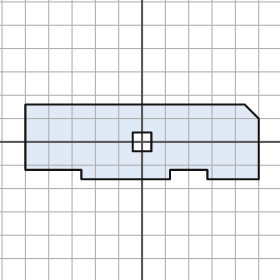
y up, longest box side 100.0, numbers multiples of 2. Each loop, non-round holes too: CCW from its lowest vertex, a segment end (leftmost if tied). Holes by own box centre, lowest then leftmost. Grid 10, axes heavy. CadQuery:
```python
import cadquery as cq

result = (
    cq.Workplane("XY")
    .moveTo(-26.0, -16.0)
    .lineTo(12.0, -16.0)
    .lineTo(12.0, -12.0)
    .lineTo(28.0, -12.0)
    .lineTo(28.0, -16.0)
    .lineTo(50.0, -16.0)
    .lineTo(50.0, 10.0)
    .lineTo(44.0, 16.0)
    .lineTo(-50.0, 16.0)
    .lineTo(-50.0, -12.0)
    .lineTo(-26.0, -12.0)
    .close()
    .moveTo(-4.0, -4.0)
    .lineTo(4.0, -4.0)
    .lineTo(4.0, 4.0)
    .lineTo(-4.0, 4.0)
    .close()
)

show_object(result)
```